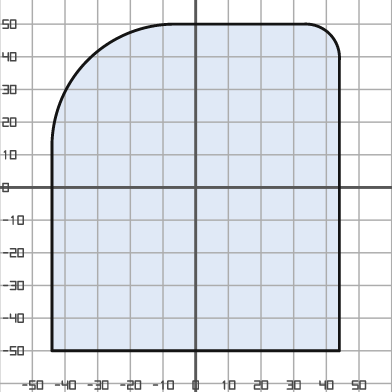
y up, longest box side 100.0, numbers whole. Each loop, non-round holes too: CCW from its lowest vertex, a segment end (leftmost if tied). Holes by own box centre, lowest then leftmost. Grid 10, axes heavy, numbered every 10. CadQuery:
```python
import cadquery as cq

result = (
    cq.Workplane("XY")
    .moveTo(-44.0, -50.0)
    .lineTo(44.0, -50.0)
    .lineTo(44.0, 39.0)
    .threePointArc((41.0, 47.0), (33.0, 50.0))
    .lineTo(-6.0, 50.0)
    .threePointArc((-33.0, 39.0), (-44.0, 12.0))
    .close()
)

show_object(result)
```